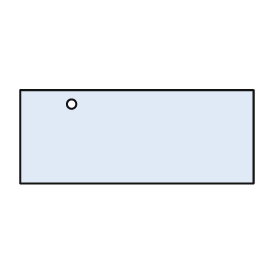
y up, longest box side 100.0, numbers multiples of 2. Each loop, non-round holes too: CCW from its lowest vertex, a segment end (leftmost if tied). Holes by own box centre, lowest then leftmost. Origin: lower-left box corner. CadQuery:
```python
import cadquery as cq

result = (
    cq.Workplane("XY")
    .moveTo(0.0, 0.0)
    .lineTo(100.0, 0.0)
    .lineTo(100.0, 40.0)
    .lineTo(0.0, 40.0)
    .close()
    .moveTo(22.0, 34.0)
    .circle(2.0)
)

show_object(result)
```